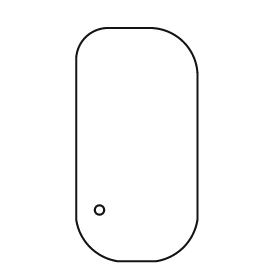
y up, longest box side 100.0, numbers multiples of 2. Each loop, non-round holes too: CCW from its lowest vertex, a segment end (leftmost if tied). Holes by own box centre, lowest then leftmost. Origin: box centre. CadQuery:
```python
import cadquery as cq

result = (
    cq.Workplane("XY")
    .moveTo(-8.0, -50.0)
    .lineTo(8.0, -50.0)
    .threePointArc((20.0, -44.0), (26.0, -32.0))
    .lineTo(26.0, 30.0)
    .threePointArc((20.0, 44.0), (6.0, 50.0))
    .lineTo(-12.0, 50.0)
    .threePointArc((-22.0, 46.0), (-26.0, 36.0))
    .lineTo(-26.0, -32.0)
    .threePointArc((-20.0, -44.0), (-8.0, -50.0))
    .close()
    .moveTo(-16.0, -28.0)
    .circle(2.0)
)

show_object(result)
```